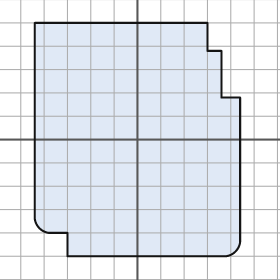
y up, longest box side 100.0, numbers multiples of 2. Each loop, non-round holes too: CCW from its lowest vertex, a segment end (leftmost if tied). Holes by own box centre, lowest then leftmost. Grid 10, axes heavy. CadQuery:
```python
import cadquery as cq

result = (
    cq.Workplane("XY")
    .moveTo(-30.0, -50.0)
    .lineTo(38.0, -50.0)
    .threePointArc((42.0, -48.0), (44.0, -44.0))
    .lineTo(44.0, 18.0)
    .lineTo(36.0, 18.0)
    .lineTo(36.0, 38.0)
    .lineTo(30.0, 38.0)
    .lineTo(30.0, 50.0)
    .lineTo(-44.0, 50.0)
    .lineTo(-44.0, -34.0)
    .threePointArc((-42.0, -38.0), (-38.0, -40.0))
    .lineTo(-30.0, -40.0)
    .close()
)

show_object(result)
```